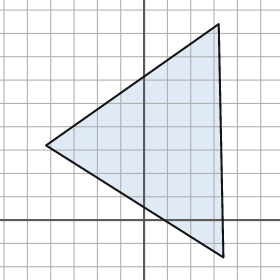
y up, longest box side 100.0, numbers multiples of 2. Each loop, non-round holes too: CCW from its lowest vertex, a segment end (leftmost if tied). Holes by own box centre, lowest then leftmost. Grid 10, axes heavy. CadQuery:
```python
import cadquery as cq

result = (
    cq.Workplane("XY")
    .moveTo(34.0, -16.0)
    .lineTo(32.0, 84.0)
    .lineTo(-42.0, 32.0)
    .close()
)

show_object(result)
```